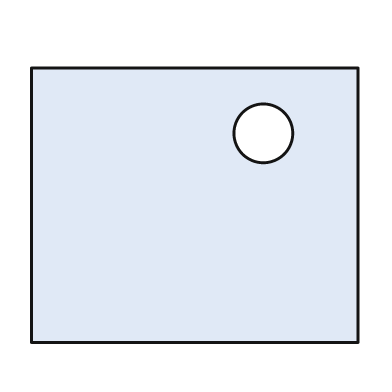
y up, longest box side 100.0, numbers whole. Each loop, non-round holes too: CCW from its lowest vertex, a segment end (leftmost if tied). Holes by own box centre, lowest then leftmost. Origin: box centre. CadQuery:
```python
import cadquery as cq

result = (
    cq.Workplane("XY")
    .moveTo(-50.0, -42.0)
    .lineTo(50.0, -42.0)
    .lineTo(50.0, 42.0)
    .lineTo(-50.0, 42.0)
    .close()
    .moveTo(21.0, 22.0)
    .circle(9.0)
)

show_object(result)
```